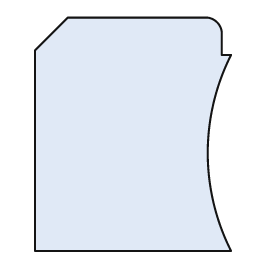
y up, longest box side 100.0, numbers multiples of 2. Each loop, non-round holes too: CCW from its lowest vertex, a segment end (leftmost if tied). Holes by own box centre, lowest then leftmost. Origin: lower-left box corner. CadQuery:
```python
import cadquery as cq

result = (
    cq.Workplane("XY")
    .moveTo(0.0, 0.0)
    .lineTo(84.0, 0.0)
    .threePointArc((74.0, 42.0), (84.0, 84.0))
    .lineTo(80.0, 84.0)
    .lineTo(80.0, 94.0)
    .threePointArc((78.0, 98.0), (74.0, 100.0))
    .lineTo(14.0, 100.0)
    .lineTo(0.0, 86.0)
    .close()
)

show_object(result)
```